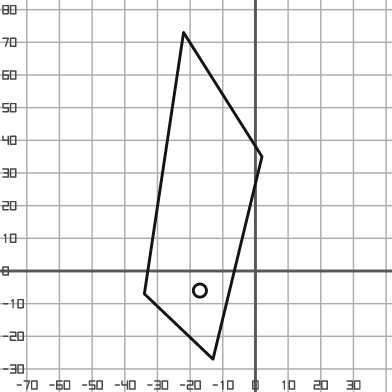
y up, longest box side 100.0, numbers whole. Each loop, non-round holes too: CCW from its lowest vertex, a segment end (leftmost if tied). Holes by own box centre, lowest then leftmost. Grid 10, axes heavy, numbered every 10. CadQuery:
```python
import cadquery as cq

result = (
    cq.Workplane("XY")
    .moveTo(-13.0, -27.0)
    .lineTo(2.0, 35.0)
    .lineTo(-22.0, 73.0)
    .lineTo(-34.0, -7.0)
    .close()
    .moveTo(-17.0, -6.0)
    .circle(2.0)
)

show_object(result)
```